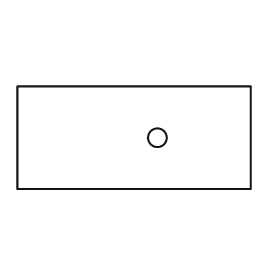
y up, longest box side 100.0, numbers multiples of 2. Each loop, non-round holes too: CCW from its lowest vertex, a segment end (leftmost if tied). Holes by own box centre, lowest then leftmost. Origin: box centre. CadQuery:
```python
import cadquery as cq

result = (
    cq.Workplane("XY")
    .moveTo(-50.0, -22.0)
    .lineTo(50.0, -22.0)
    .lineTo(50.0, 22.0)
    .lineTo(-50.0, 22.0)
    .close()
    .moveTo(10.0, 0.0)
    .circle(4.0)
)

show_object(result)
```